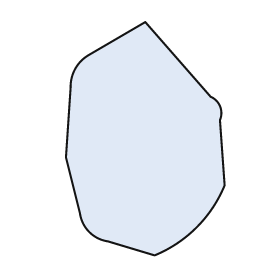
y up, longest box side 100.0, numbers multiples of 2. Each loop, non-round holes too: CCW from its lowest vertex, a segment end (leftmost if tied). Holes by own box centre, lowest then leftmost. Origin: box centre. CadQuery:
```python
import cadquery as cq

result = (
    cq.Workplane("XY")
    .moveTo(4.0, -50.0)
    .threePointArc((22.0, -38.0), (34.0, -20.0))
    .lineTo(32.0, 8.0)
    .threePointArc((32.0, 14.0), (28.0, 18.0))
    .lineTo(0.0, 50.0)
    .lineTo(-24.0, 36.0)
    .threePointArc((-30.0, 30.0), (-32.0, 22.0))
    .lineTo(-34.0, -8.0)
    .lineTo(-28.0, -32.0)
    .threePointArc((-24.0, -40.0), (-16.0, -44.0))
    .close()
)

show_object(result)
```